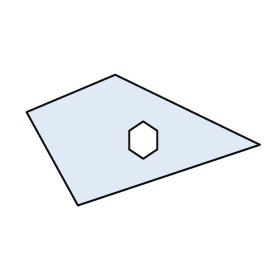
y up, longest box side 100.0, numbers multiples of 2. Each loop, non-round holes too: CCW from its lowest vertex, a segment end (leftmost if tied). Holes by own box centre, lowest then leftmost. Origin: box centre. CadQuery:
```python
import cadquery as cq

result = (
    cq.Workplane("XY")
    .moveTo(-28.0, -28.0)
    .lineTo(50.0, -2.0)
    .lineTo(-12.0, 28.0)
    .lineTo(-50.0, 12.0)
    .close()
    .moveTo(0.0, -8.0)
    .lineTo(6.0, -4.0)
    .lineTo(6.0, 4.0)
    .lineTo(0.0, 8.0)
    .lineTo(-6.0, 4.0)
    .lineTo(-6.0, -4.0)
    .close()
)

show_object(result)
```